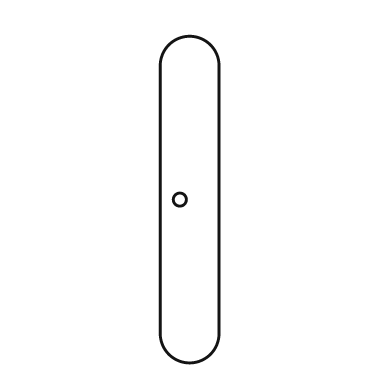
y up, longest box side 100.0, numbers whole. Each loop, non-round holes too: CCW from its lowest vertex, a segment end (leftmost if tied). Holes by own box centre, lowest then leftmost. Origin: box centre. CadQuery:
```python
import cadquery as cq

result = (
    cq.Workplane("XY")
    .moveTo(-9.0, -41.0)
    .threePointArc((0.0, -50.0), (9.0, -41.0))
    .lineTo(9.0, 41.0)
    .threePointArc((0.0, 50.0), (-9.0, 41.0))
    .close()
    .moveTo(-3.0, 0.0)
    .circle(2.0)
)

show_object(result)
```